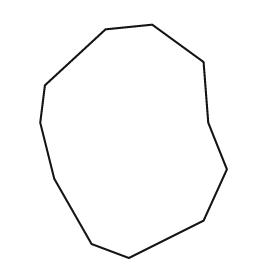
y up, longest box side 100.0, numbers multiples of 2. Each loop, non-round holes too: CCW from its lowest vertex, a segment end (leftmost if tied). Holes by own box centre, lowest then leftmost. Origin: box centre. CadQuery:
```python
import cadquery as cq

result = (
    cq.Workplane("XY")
    .moveTo(-2.0, -50.0)
    .lineTo(30.0, -34.0)
    .lineTo(40.0, -12.0)
    .lineTo(32.0, 8.0)
    .lineTo(30.0, 34.0)
    .lineTo(8.0, 50.0)
    .lineTo(-12.0, 48.0)
    .lineTo(-38.0, 24.0)
    .lineTo(-40.0, 8.0)
    .lineTo(-34.0, -16.0)
    .lineTo(-18.0, -44.0)
    .close()
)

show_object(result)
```